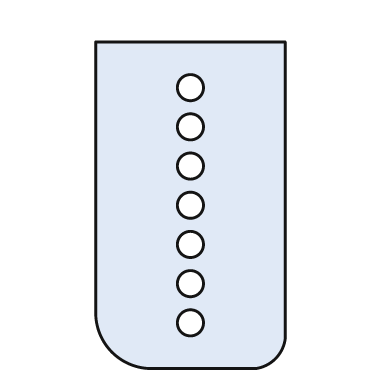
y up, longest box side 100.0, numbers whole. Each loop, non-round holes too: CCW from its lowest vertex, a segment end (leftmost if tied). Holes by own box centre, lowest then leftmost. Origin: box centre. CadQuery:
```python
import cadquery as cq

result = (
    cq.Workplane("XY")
    .moveTo(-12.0, -50.0)
    .lineTo(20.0, -50.0)
    .threePointArc((26.0, -47.0), (29.0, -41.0))
    .lineTo(29.0, 50.0)
    .lineTo(-29.0, 50.0)
    .lineTo(-29.0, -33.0)
    .threePointArc((-24.0, -45.0), (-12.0, -50.0))
    .close()
    .moveTo(0.0, -36.0)
    .circle(4.0)
    .moveTo(0.0, -24.0)
    .circle(4.0)
    .moveTo(0.0, -12.0)
    .circle(4.0)
    .moveTo(0.0, 0.0)
    .circle(4.0)
    .moveTo(0.0, 12.0)
    .circle(4.0)
    .moveTo(0.0, 24.0)
    .circle(4.0)
    .moveTo(0.0, 36.0)
    .circle(4.0)
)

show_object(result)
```